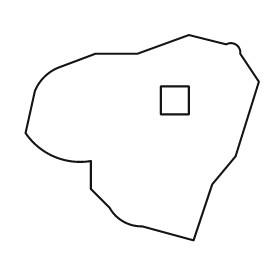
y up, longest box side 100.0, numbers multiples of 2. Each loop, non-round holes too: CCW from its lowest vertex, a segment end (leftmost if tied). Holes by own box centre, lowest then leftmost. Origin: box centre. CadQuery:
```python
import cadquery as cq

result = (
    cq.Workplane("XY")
    .moveTo(22.0, -44.0)
    .lineTo(30.0, -20.0)
    .lineTo(40.0, -8.0)
    .lineTo(50.0, 24.0)
    .lineTo(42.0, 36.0)
    .threePointArc((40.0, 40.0), (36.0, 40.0))
    .lineTo(20.0, 44.0)
    .lineTo(-2.0, 36.0)
    .lineTo(-20.0, 36.0)
    .lineTo(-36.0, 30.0)
    .threePointArc((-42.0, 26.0), (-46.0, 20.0))
    .lineTo(-50.0, 2.0)
    .threePointArc((-38.0, -8.0), (-22.0, -10.0))
    .lineTo(-22.0, -22.0)
    .lineTo(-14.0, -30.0)
    .threePointArc((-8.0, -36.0), (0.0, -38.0))
    .close()
    .moveTo(8.0, 10.0)
    .lineTo(20.0, 10.0)
    .lineTo(20.0, 22.0)
    .lineTo(8.0, 22.0)
    .close()
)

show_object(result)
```